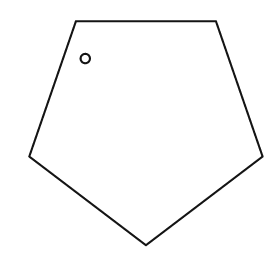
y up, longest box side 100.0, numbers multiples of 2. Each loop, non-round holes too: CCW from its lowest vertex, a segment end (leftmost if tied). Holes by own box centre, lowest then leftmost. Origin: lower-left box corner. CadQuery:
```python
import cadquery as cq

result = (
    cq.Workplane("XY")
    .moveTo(50.0, 0.0)
    .lineTo(100.0, 38.0)
    .lineTo(80.0, 96.0)
    .lineTo(20.0, 96.0)
    .lineTo(0.0, 38.0)
    .close()
    .moveTo(24.0, 80.0)
    .circle(2.0)
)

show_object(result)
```